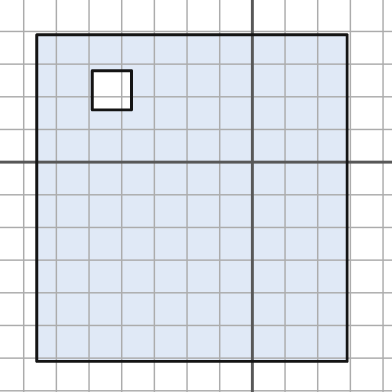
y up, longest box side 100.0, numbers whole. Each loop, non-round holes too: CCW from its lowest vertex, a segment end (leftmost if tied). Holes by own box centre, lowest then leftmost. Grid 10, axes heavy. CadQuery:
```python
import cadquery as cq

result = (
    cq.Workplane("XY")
    .moveTo(-66.0, -61.0)
    .lineTo(29.0, -61.0)
    .lineTo(29.0, 39.0)
    .lineTo(-66.0, 39.0)
    .close()
    .moveTo(-49.0, 16.0)
    .lineTo(-37.0, 16.0)
    .lineTo(-37.0, 28.0)
    .lineTo(-49.0, 28.0)
    .close()
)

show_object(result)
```